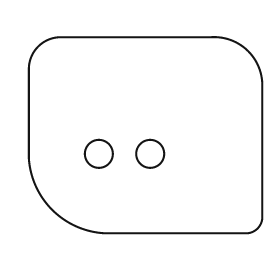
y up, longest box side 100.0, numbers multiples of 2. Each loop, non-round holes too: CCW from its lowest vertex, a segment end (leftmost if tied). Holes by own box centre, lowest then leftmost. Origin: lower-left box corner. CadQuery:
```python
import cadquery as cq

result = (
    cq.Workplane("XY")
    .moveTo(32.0, 0.0)
    .lineTo(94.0, 0.0)
    .threePointArc((98.0, 2.0), (100.0, 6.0))
    .lineTo(100.0, 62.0)
    .threePointArc((94.0, 78.0), (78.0, 84.0))
    .lineTo(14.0, 84.0)
    .threePointArc((4.0, 80.0), (0.0, 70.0))
    .lineTo(0.0, 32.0)
    .threePointArc((10.0, 10.0), (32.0, 0.0))
    .close()
    .moveTo(30.0, 34.0)
    .circle(6.0)
    .moveTo(52.0, 34.0)
    .circle(6.0)
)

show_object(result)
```